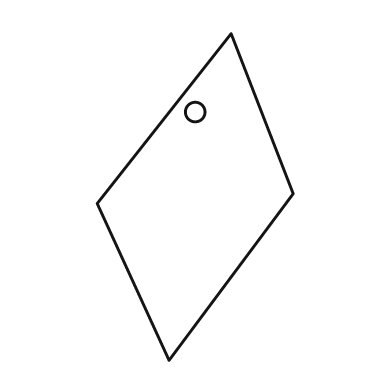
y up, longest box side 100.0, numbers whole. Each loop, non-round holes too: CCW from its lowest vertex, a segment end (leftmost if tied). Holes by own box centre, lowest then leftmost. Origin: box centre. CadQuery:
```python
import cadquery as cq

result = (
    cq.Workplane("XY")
    .moveTo(-8.0, -50.0)
    .lineTo(30.0, 1.0)
    .lineTo(11.0, 50.0)
    .lineTo(-30.0, -2.0)
    .close()
    .moveTo(0.0, 26.0)
    .circle(3.0)
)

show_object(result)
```